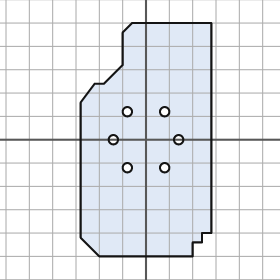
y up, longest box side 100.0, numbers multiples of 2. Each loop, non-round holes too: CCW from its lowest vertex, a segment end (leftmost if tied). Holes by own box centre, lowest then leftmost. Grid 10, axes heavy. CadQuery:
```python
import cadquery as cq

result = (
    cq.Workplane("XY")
    .moveTo(-20.0, -50.0)
    .lineTo(20.0, -50.0)
    .lineTo(20.0, -44.0)
    .lineTo(24.0, -44.0)
    .lineTo(24.0, -40.0)
    .lineTo(28.0, -40.0)
    .lineTo(28.0, 50.0)
    .lineTo(-6.0, 50.0)
    .lineTo(-10.0, 46.0)
    .lineTo(-10.0, 32.0)
    .lineTo(-18.0, 24.0)
    .lineTo(-22.0, 24.0)
    .lineTo(-28.0, 16.0)
    .lineTo(-28.0, -42.0)
    .close()
    .moveTo(-8.0, -12.0)
    .circle(2.0)
    .moveTo(8.0, -12.0)
    .circle(2.0)
    .moveTo(-14.0, 0.0)
    .circle(2.0)
    .moveTo(14.0, 0.0)
    .circle(2.0)
    .moveTo(-8.0, 12.0)
    .circle(2.0)
    .moveTo(8.0, 12.0)
    .circle(2.0)
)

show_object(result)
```